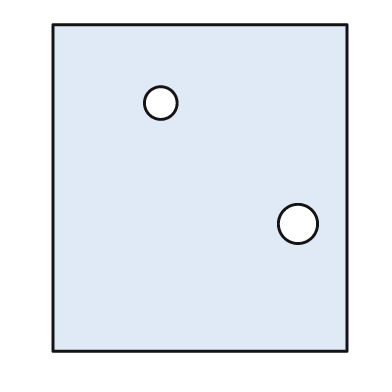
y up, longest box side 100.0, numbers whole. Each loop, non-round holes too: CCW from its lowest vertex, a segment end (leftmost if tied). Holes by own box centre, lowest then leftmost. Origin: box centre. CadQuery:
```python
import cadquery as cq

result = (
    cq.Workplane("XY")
    .moveTo(-45.0, -50.0)
    .lineTo(45.0, -50.0)
    .lineTo(45.0, 50.0)
    .lineTo(-45.0, 50.0)
    .close()
    .moveTo(30.0, -11.0)
    .circle(6.0)
    .moveTo(-12.0, 26.0)
    .circle(5.0)
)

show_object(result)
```